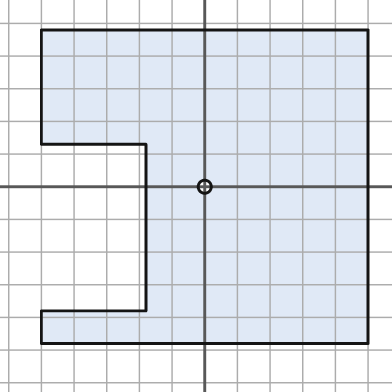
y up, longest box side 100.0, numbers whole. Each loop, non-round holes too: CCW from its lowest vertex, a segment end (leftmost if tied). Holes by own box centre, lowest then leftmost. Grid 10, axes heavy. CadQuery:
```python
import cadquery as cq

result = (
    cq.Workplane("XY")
    .moveTo(-50.0, -48.0)
    .lineTo(50.0, -48.0)
    .lineTo(50.0, 48.0)
    .lineTo(-50.0, 48.0)
    .lineTo(-50.0, 13.0)
    .lineTo(-18.0, 13.0)
    .lineTo(-18.0, -38.0)
    .lineTo(-50.0, -38.0)
    .close()
    .moveTo(0.0, 0.0)
    .circle(2.0)
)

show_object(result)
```